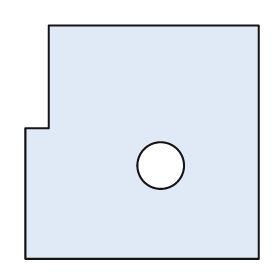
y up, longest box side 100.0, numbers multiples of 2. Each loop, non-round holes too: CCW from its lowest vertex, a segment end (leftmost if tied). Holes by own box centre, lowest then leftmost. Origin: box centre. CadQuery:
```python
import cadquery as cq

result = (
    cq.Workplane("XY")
    .moveTo(-50.0, -50.0)
    .lineTo(50.0, -50.0)
    .lineTo(50.0, 50.0)
    .lineTo(-40.0, 50.0)
    .lineTo(-40.0, 6.0)
    .lineTo(-50.0, 6.0)
    .close()
    .moveTo(8.0, -10.0)
    .circle(10.0)
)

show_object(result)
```